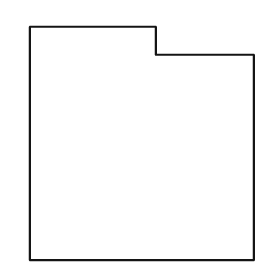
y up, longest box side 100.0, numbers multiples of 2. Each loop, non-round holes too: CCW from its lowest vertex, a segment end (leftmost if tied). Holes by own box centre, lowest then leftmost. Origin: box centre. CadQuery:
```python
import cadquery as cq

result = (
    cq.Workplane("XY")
    .moveTo(-48.0, -50.0)
    .lineTo(48.0, -50.0)
    .lineTo(48.0, 38.0)
    .lineTo(6.0, 38.0)
    .lineTo(6.0, 50.0)
    .lineTo(-48.0, 50.0)
    .close()
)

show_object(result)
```